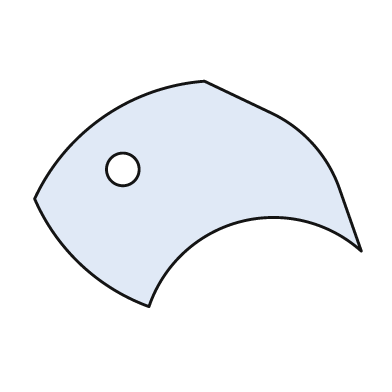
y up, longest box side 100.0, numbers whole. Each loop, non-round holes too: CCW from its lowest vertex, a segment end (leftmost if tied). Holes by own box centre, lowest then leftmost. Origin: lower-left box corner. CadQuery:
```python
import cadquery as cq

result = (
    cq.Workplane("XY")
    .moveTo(35.0, 0.0)
    .threePointArc((63.0, 26.0), (100.0, 17.0))
    .lineTo(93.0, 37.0)
    .threePointArc((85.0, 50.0), (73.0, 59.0))
    .lineTo(52.0, 69.0)
    .threePointArc((21.0, 58.0), (0.0, 33.0))
    .threePointArc((14.0, 13.0), (35.0, 0.0))
    .close()
    .moveTo(27.0, 42.0)
    .circle(5.0)
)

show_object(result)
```